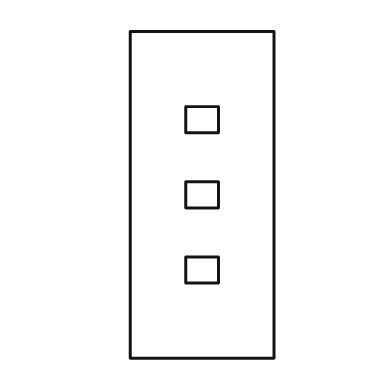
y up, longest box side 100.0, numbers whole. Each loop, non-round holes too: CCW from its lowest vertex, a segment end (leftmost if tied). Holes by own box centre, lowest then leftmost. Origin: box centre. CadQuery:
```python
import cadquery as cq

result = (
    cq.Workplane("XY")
    .moveTo(-22.0, -50.0)
    .lineTo(22.0, -50.0)
    .lineTo(22.0, 50.0)
    .lineTo(-22.0, 50.0)
    .close()
    .moveTo(-5.0, -27.0)
    .lineTo(5.0, -27.0)
    .lineTo(5.0, -19.0)
    .lineTo(-5.0, -19.0)
    .close()
    .moveTo(-5.0, -4.0)
    .lineTo(5.0, -4.0)
    .lineTo(5.0, 4.0)
    .lineTo(-5.0, 4.0)
    .close()
    .moveTo(-5.0, 19.0)
    .lineTo(5.0, 19.0)
    .lineTo(5.0, 27.0)
    .lineTo(-5.0, 27.0)
    .close()
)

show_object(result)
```